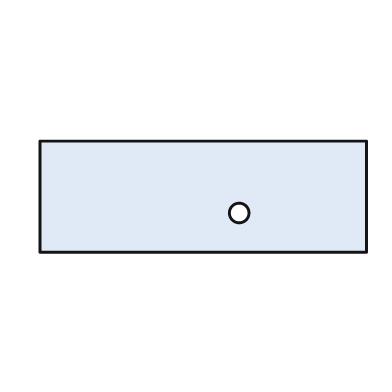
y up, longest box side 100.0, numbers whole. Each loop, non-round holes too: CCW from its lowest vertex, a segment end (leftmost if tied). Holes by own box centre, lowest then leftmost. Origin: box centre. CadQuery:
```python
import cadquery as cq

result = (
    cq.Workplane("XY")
    .moveTo(-50.0, -17.0)
    .lineTo(50.0, -17.0)
    .lineTo(50.0, 17.0)
    .lineTo(-50.0, 17.0)
    .close()
    .moveTo(11.0, -5.0)
    .circle(3.0)
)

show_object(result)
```